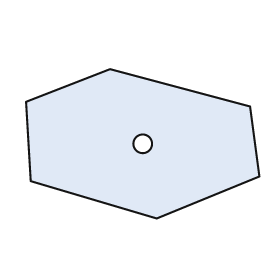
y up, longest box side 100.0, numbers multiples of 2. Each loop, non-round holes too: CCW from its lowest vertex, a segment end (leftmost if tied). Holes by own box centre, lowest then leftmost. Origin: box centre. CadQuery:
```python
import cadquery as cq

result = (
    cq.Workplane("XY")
    .moveTo(6.0, -32.0)
    .lineTo(50.0, -14.0)
    .lineTo(46.0, 16.0)
    .lineTo(-14.0, 32.0)
    .lineTo(-50.0, 18.0)
    .lineTo(-48.0, -16.0)
    .close()
    .moveTo(0.0, 0.0)
    .circle(4.0)
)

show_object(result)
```